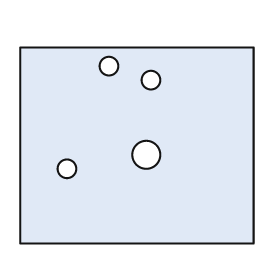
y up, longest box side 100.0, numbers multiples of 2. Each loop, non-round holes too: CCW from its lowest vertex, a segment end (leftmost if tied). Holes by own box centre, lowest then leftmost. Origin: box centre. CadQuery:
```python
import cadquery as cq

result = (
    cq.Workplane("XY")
    .moveTo(-50.0, -42.0)
    .lineTo(50.0, -42.0)
    .lineTo(50.0, 42.0)
    .lineTo(-50.0, 42.0)
    .close()
    .moveTo(-30.0, -10.0)
    .circle(4.0)
    .moveTo(4.0, -4.0)
    .circle(6.0)
    .moveTo(6.0, 28.0)
    .circle(4.0)
    .moveTo(-12.0, 34.0)
    .circle(4.0)
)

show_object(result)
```